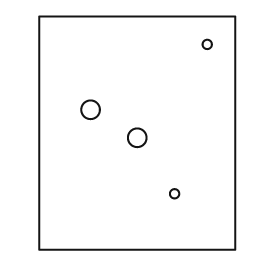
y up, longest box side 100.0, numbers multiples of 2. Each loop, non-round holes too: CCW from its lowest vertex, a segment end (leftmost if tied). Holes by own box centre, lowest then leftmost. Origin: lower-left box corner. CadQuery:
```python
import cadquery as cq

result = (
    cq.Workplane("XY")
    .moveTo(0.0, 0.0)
    .lineTo(84.0, 0.0)
    .lineTo(84.0, 100.0)
    .lineTo(0.0, 100.0)
    .close()
    .moveTo(58.0, 24.0)
    .circle(2.0)
    .moveTo(42.0, 48.0)
    .circle(4.0)
    .moveTo(22.0, 60.0)
    .circle(4.0)
    .moveTo(72.0, 88.0)
    .circle(2.0)
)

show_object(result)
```